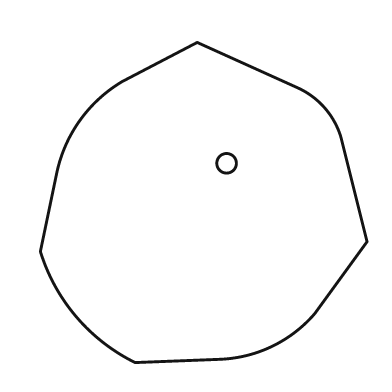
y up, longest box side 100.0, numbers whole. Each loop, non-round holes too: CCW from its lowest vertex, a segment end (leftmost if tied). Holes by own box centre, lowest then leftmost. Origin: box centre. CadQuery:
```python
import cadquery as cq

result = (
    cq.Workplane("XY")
    .moveTo(-21.0, -49.0)
    .lineTo(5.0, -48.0)
    .threePointArc((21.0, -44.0), (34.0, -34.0))
    .lineTo(50.0, -12.0)
    .lineTo(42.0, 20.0)
    .threePointArc((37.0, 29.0), (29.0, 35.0))
    .lineTo(-2.0, 49.0)
    .lineTo(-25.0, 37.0)
    .threePointArc((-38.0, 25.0), (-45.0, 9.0))
    .lineTo(-50.0, -15.0)
    .threePointArc((-39.0, -35.0), (-21.0, -49.0))
    .close()
    .moveTo(7.0, 12.0)
    .circle(3.0)
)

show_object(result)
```